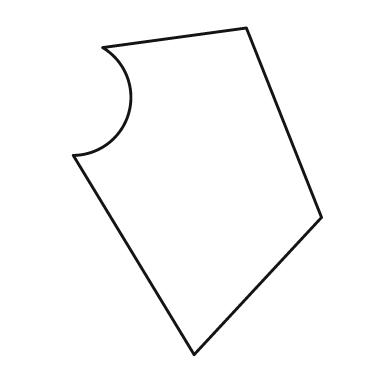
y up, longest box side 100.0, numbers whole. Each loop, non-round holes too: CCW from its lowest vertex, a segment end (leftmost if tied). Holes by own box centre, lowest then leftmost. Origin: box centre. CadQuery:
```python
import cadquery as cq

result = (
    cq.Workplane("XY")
    .moveTo(-1.0, -50.0)
    .lineTo(38.0, -8.0)
    .lineTo(15.0, 50.0)
    .lineTo(-29.0, 44.0)
    .threePointArc((-21.0, 24.0), (-38.0, 11.0))
    .close()
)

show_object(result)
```